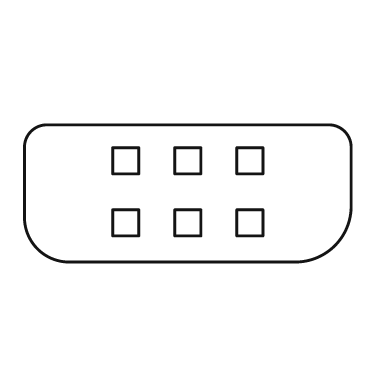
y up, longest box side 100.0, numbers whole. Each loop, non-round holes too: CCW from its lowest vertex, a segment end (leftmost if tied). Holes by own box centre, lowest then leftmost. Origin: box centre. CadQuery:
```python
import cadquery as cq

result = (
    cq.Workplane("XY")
    .moveTo(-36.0, -21.0)
    .lineTo(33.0, -21.0)
    .threePointArc((45.0, -16.0), (50.0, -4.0))
    .lineTo(50.0, 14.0)
    .threePointArc((48.0, 19.0), (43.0, 21.0))
    .lineTo(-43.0, 21.0)
    .threePointArc((-48.0, 19.0), (-50.0, 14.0))
    .lineTo(-50.0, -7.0)
    .threePointArc((-46.0, -17.0), (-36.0, -21.0))
    .close()
    .moveTo(-23.0, -13.0)
    .lineTo(-15.0, -13.0)
    .lineTo(-15.0, -5.0)
    .lineTo(-23.0, -5.0)
    .close()
    .moveTo(-4.0, -13.0)
    .lineTo(4.0, -13.0)
    .lineTo(4.0, -5.0)
    .lineTo(-4.0, -5.0)
    .close()
    .moveTo(15.0, -13.0)
    .lineTo(23.0, -13.0)
    .lineTo(23.0, -5.0)
    .lineTo(15.0, -5.0)
    .close()
    .moveTo(-23.0, 6.0)
    .lineTo(-15.0, 6.0)
    .lineTo(-15.0, 14.0)
    .lineTo(-23.0, 14.0)
    .close()
    .moveTo(-4.0, 6.0)
    .lineTo(4.0, 6.0)
    .lineTo(4.0, 14.0)
    .lineTo(-4.0, 14.0)
    .close()
    .moveTo(15.0, 6.0)
    .lineTo(23.0, 6.0)
    .lineTo(23.0, 14.0)
    .lineTo(15.0, 14.0)
    .close()
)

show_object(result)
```